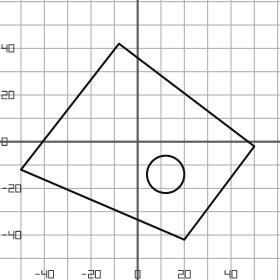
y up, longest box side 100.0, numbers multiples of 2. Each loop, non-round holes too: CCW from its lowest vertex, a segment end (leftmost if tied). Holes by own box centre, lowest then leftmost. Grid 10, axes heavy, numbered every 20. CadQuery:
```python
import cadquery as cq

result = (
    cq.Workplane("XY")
    .moveTo(20.0, -42.0)
    .lineTo(50.0, -2.0)
    .lineTo(-8.0, 42.0)
    .lineTo(-50.0, -12.0)
    .close()
    .moveTo(12.0, -14.0)
    .circle(8.0)
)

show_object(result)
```